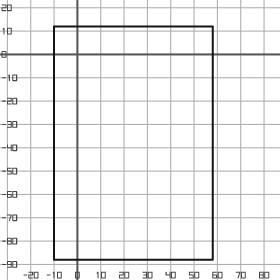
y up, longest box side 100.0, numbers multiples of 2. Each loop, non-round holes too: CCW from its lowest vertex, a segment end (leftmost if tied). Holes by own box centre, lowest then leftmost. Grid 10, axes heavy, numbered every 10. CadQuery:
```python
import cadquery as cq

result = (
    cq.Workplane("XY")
    .moveTo(-10.0, -88.0)
    .lineTo(58.0, -88.0)
    .lineTo(58.0, 12.0)
    .lineTo(-10.0, 12.0)
    .close()
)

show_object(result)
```